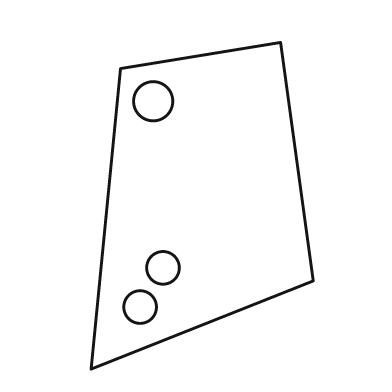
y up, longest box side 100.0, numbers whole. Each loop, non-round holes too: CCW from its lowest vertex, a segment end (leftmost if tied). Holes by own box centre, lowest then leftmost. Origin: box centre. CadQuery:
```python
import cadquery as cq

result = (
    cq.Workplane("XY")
    .moveTo(-34.0, -50.0)
    .lineTo(34.0, -23.0)
    .lineTo(24.0, 50.0)
    .lineTo(-25.0, 42.0)
    .close()
    .moveTo(-19.0, -31.0)
    .circle(5.0)
    .moveTo(-12.0, -19.0)
    .circle(5.0)
    .moveTo(-15.0, 32.0)
    .circle(6.0)
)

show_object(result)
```